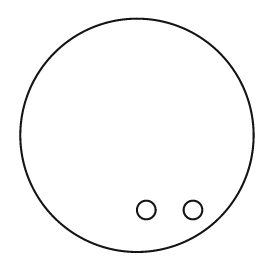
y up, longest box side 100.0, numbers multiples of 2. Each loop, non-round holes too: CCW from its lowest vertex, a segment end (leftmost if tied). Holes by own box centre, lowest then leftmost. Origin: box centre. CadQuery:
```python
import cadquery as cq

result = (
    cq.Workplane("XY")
    .moveTo(0.0, 0.0)
    .circle(50.0)
    .moveTo(4.0, -32.0)
    .circle(4.0)
    .moveTo(24.0, -32.0)
    .circle(4.0)
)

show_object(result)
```